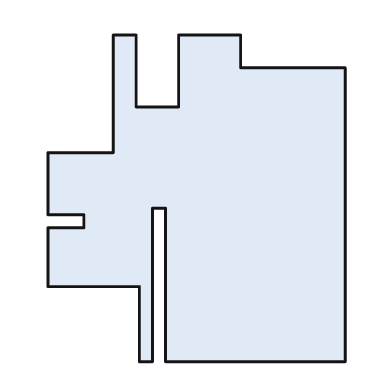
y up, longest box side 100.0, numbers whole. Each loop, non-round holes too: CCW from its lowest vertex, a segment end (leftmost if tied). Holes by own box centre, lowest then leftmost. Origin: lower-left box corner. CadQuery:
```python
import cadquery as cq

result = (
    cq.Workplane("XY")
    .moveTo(28.0, 0.0)
    .lineTo(32.0, 0.0)
    .lineTo(32.0, 47.0)
    .lineTo(36.0, 47.0)
    .lineTo(36.0, 0.0)
    .lineTo(91.0, 0.0)
    .lineTo(91.0, 90.0)
    .lineTo(59.0, 90.0)
    .lineTo(59.0, 100.0)
    .lineTo(40.0, 100.0)
    .lineTo(40.0, 78.0)
    .lineTo(27.0, 78.0)
    .lineTo(27.0, 100.0)
    .lineTo(20.0, 100.0)
    .lineTo(20.0, 64.0)
    .lineTo(0.0, 64.0)
    .lineTo(0.0, 45.0)
    .lineTo(11.0, 45.0)
    .lineTo(11.0, 41.0)
    .lineTo(0.0, 41.0)
    .lineTo(0.0, 23.0)
    .lineTo(28.0, 23.0)
    .close()
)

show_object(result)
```